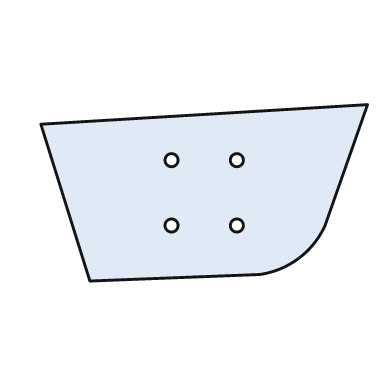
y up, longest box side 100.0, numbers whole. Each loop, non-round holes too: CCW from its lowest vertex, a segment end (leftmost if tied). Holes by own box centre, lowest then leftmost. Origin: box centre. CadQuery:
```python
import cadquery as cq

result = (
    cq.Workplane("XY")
    .moveTo(-35.0, -27.0)
    .lineTo(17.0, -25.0)
    .threePointArc((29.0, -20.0), (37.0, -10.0))
    .lineTo(50.0, 27.0)
    .lineTo(-50.0, 21.0)
    .close()
    .moveTo(-10.0, -10.0)
    .circle(2.0)
    .moveTo(10.0, -10.0)
    .circle(2.0)
    .moveTo(-10.0, 10.0)
    .circle(2.0)
    .moveTo(10.0, 10.0)
    .circle(2.0)
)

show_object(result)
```